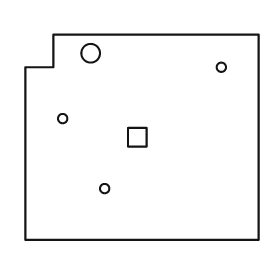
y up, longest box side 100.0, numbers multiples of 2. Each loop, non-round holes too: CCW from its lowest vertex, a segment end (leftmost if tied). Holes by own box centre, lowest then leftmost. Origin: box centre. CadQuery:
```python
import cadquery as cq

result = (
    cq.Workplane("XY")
    .moveTo(-50.0, -44.0)
    .lineTo(50.0, -44.0)
    .lineTo(50.0, 44.0)
    .lineTo(-38.0, 44.0)
    .lineTo(-38.0, 30.0)
    .lineTo(-50.0, 30.0)
    .close()
    .moveTo(-16.0, -22.0)
    .circle(2.0)
    .moveTo(-6.0, -4.0)
    .lineTo(2.0, -4.0)
    .lineTo(2.0, 4.0)
    .lineTo(-6.0, 4.0)
    .close()
    .moveTo(-34.0, 8.0)
    .circle(2.0)
    .moveTo(34.0, 30.0)
    .circle(2.0)
    .moveTo(-22.0, 36.0)
    .circle(4.0)
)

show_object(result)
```